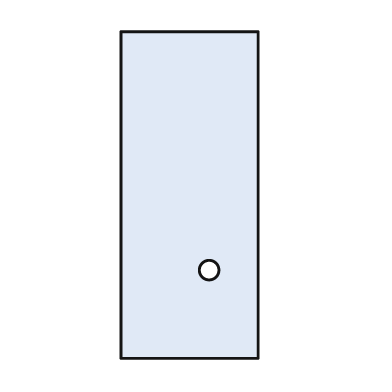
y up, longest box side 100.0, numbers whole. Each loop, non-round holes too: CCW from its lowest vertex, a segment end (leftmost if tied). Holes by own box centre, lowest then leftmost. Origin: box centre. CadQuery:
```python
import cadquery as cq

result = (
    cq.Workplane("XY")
    .moveTo(-21.0, -50.0)
    .lineTo(21.0, -50.0)
    .lineTo(21.0, 50.0)
    .lineTo(-21.0, 50.0)
    .close()
    .moveTo(6.0, -23.0)
    .circle(3.0)
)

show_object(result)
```